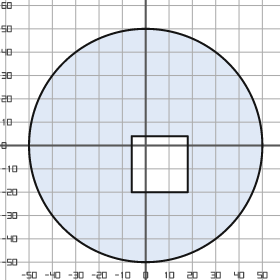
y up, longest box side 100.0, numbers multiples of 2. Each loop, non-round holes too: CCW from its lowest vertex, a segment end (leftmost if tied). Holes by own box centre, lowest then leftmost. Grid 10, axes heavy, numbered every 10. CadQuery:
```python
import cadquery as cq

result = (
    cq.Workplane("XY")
    .moveTo(0.0, 0.0)
    .circle(50.0)
    .moveTo(-6.0, -20.0)
    .lineTo(18.0, -20.0)
    .lineTo(18.0, 4.0)
    .lineTo(-6.0, 4.0)
    .close()
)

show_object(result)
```